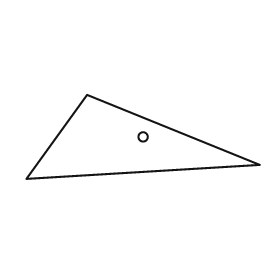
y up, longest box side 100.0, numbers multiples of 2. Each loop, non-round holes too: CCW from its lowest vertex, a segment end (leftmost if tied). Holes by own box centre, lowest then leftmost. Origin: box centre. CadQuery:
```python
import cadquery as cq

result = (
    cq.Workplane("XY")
    .moveTo(-50.0, -18.0)
    .lineTo(50.0, -12.0)
    .lineTo(-24.0, 18.0)
    .close()
    .moveTo(0.0, 0.0)
    .circle(2.0)
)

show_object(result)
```